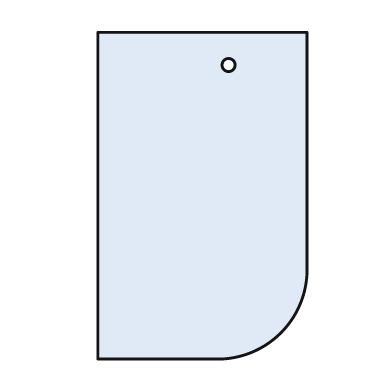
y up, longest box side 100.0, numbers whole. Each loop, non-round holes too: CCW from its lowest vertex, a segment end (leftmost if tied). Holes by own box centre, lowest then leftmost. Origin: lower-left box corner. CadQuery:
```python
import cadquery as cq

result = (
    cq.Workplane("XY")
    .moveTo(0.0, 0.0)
    .lineTo(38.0, 0.0)
    .threePointArc((56.0, 8.0), (64.0, 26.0))
    .lineTo(64.0, 100.0)
    .lineTo(0.0, 100.0)
    .close()
    .moveTo(40.0, 90.0)
    .circle(2.0)
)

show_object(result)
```